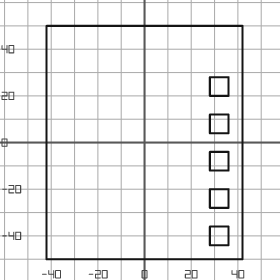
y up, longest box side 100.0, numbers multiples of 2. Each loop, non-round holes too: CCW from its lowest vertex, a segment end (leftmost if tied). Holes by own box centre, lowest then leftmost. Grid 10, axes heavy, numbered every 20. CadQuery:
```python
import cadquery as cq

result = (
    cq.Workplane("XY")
    .moveTo(-42.0, -50.0)
    .lineTo(42.0, -50.0)
    .lineTo(42.0, 50.0)
    .lineTo(-42.0, 50.0)
    .close()
    .moveTo(28.0, -44.0)
    .lineTo(36.0, -44.0)
    .lineTo(36.0, -36.0)
    .lineTo(28.0, -36.0)
    .close()
    .moveTo(28.0, -28.0)
    .lineTo(36.0, -28.0)
    .lineTo(36.0, -20.0)
    .lineTo(28.0, -20.0)
    .close()
    .moveTo(28.0, -12.0)
    .lineTo(36.0, -12.0)
    .lineTo(36.0, -4.0)
    .lineTo(28.0, -4.0)
    .close()
    .moveTo(28.0, 4.0)
    .lineTo(36.0, 4.0)
    .lineTo(36.0, 12.0)
    .lineTo(28.0, 12.0)
    .close()
    .moveTo(28.0, 20.0)
    .lineTo(36.0, 20.0)
    .lineTo(36.0, 28.0)
    .lineTo(28.0, 28.0)
    .close()
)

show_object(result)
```